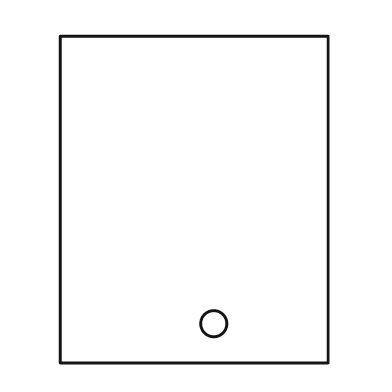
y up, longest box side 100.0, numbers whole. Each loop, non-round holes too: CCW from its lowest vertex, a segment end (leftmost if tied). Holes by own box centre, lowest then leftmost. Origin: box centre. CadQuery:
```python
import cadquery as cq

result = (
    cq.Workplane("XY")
    .moveTo(-41.0, -50.0)
    .lineTo(41.0, -50.0)
    .lineTo(41.0, 50.0)
    .lineTo(-41.0, 50.0)
    .close()
    .moveTo(6.0, -38.0)
    .circle(4.0)
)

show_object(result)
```